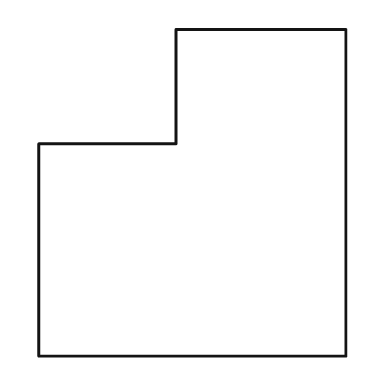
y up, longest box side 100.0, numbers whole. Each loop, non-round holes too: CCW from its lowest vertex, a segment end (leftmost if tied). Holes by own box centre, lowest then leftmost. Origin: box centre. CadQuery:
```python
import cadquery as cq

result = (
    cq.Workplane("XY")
    .moveTo(-47.0, -50.0)
    .lineTo(47.0, -50.0)
    .lineTo(47.0, 50.0)
    .lineTo(-5.0, 50.0)
    .lineTo(-5.0, 15.0)
    .lineTo(-47.0, 15.0)
    .close()
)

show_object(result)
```